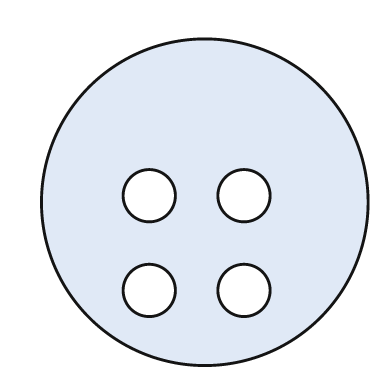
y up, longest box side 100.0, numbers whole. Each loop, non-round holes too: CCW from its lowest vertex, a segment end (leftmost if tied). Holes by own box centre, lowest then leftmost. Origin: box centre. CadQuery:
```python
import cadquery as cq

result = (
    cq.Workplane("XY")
    .moveTo(0.0, 0.0)
    .circle(50.0)
    .moveTo(-17.0, -27.0)
    .circle(8.0)
    .moveTo(12.0, -27.0)
    .circle(8.0)
    .moveTo(-17.0, 2.0)
    .circle(8.0)
    .moveTo(12.0, 2.0)
    .circle(8.0)
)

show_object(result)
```